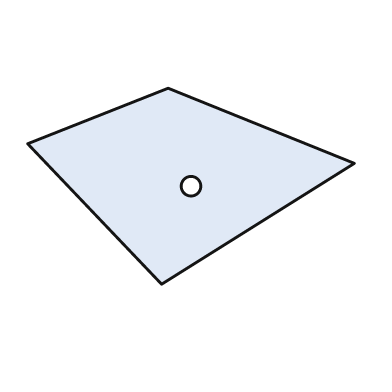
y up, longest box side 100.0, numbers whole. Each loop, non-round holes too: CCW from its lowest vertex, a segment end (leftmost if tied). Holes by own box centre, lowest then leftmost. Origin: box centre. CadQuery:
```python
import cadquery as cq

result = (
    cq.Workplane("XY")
    .moveTo(-9.0, -30.0)
    .lineTo(50.0, 7.0)
    .lineTo(-7.0, 30.0)
    .lineTo(-50.0, 13.0)
    .close()
    .moveTo(0.0, 0.0)
    .circle(3.0)
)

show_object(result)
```